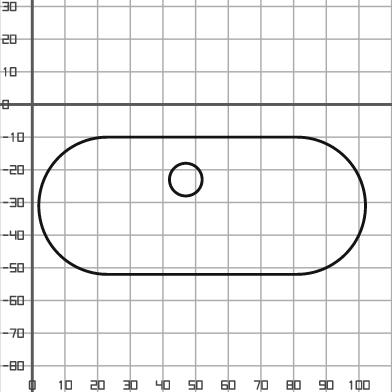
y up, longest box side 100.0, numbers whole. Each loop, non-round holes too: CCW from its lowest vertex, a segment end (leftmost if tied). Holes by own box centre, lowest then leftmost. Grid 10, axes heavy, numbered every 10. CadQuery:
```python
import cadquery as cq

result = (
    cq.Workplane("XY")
    .moveTo(23.0, -52.0)
    .lineTo(81.0, -52.0)
    .threePointArc((102.0, -31.0), (81.0, -10.0))
    .lineTo(23.0, -10.0)
    .threePointArc((2.0, -31.0), (23.0, -52.0))
    .close()
    .moveTo(47.0, -23.0)
    .circle(5.0)
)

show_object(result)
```